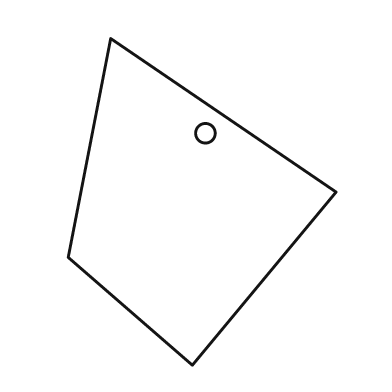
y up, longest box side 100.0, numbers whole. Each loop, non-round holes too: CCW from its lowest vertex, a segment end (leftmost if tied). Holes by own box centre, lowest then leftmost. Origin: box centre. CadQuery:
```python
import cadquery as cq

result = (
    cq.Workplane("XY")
    .moveTo(-3.0, -50.0)
    .lineTo(41.0, 3.0)
    .lineTo(-28.0, 50.0)
    .lineTo(-41.0, -17.0)
    .close()
    .moveTo(1.0, 21.0)
    .circle(3.0)
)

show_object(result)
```